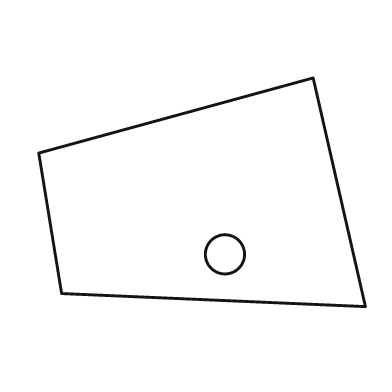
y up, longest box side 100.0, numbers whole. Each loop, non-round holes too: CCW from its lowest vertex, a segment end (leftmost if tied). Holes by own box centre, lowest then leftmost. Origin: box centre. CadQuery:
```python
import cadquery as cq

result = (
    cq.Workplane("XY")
    .moveTo(50.0, -35.0)
    .lineTo(34.0, 35.0)
    .lineTo(-50.0, 12.0)
    .lineTo(-43.0, -31.0)
    .close()
    .moveTo(7.0, -19.0)
    .circle(6.0)
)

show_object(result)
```